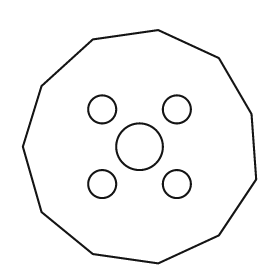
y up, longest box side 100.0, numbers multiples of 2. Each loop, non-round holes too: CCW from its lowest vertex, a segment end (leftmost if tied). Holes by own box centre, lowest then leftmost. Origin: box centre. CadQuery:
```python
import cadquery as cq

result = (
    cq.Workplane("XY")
    .moveTo(8.0, -50.0)
    .lineTo(34.0, -38.0)
    .lineTo(50.0, -14.0)
    .lineTo(48.0, 14.0)
    .lineTo(34.0, 38.0)
    .lineTo(8.0, 50.0)
    .lineTo(-20.0, 46.0)
    .lineTo(-42.0, 26.0)
    .lineTo(-50.0, 0.0)
    .lineTo(-42.0, -28.0)
    .lineTo(-20.0, -46.0)
    .close()
    .moveTo(-16.0, -16.0)
    .circle(6.0)
    .moveTo(16.0, -16.0)
    .circle(6.0)
    .moveTo(0.0, 0.0)
    .circle(10.0)
    .moveTo(-16.0, 16.0)
    .circle(6.0)
    .moveTo(16.0, 16.0)
    .circle(6.0)
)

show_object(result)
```